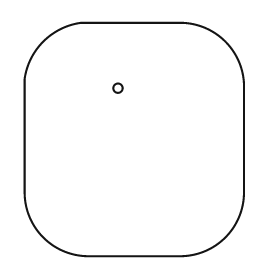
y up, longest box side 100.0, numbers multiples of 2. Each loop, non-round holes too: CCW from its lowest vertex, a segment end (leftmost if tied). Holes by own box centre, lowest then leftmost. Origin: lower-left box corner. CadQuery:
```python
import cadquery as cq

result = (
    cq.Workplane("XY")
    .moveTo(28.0, 0.0)
    .lineTo(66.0, 0.0)
    .threePointArc((86.0, 8.0), (94.0, 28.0))
    .lineTo(94.0, 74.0)
    .threePointArc((86.0, 92.0), (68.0, 100.0))
    .lineTo(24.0, 100.0)
    .threePointArc((8.0, 92.0), (0.0, 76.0))
    .lineTo(0.0, 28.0)
    .threePointArc((8.0, 8.0), (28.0, 0.0))
    .close()
    .moveTo(40.0, 72.0)
    .circle(2.0)
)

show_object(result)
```